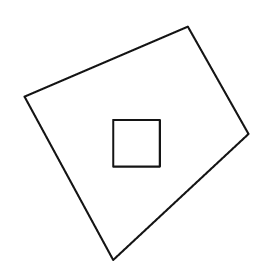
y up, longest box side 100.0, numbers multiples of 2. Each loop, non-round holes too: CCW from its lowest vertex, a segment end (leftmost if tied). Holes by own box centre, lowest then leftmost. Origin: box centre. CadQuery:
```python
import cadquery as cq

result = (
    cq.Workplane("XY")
    .moveTo(-10.0, -50.0)
    .lineTo(48.0, 4.0)
    .lineTo(22.0, 50.0)
    .lineTo(-48.0, 20.0)
    .close()
    .moveTo(-10.0, -10.0)
    .lineTo(10.0, -10.0)
    .lineTo(10.0, 10.0)
    .lineTo(-10.0, 10.0)
    .close()
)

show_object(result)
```